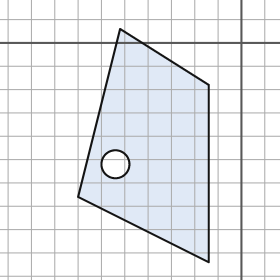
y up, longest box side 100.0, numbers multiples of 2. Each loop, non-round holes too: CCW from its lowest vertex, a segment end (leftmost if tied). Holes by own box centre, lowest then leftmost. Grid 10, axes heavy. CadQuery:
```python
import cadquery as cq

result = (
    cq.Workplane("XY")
    .moveTo(-14.0, -94.0)
    .lineTo(-14.0, -18.0)
    .lineTo(-52.0, 6.0)
    .lineTo(-70.0, -66.0)
    .close()
    .moveTo(-54.0, -52.0)
    .circle(6.0)
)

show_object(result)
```